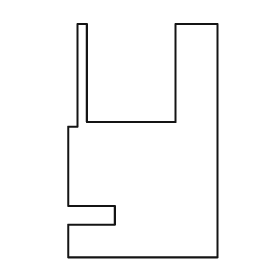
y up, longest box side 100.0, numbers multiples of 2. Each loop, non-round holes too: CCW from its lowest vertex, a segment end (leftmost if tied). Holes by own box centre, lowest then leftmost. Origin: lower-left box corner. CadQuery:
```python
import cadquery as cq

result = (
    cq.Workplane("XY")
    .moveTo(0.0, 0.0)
    .lineTo(64.0, 0.0)
    .lineTo(64.0, 100.0)
    .lineTo(46.0, 100.0)
    .lineTo(46.0, 58.0)
    .lineTo(8.0, 58.0)
    .lineTo(8.0, 100.0)
    .lineTo(4.0, 100.0)
    .lineTo(4.0, 56.0)
    .lineTo(0.0, 56.0)
    .lineTo(0.0, 22.0)
    .lineTo(20.0, 22.0)
    .lineTo(20.0, 14.0)
    .lineTo(0.0, 14.0)
    .close()
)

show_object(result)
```